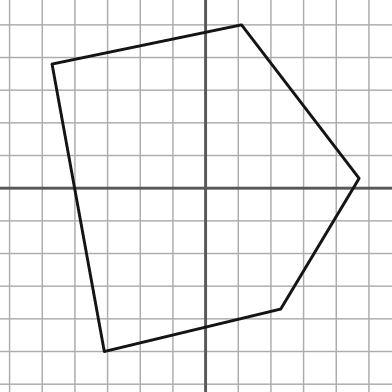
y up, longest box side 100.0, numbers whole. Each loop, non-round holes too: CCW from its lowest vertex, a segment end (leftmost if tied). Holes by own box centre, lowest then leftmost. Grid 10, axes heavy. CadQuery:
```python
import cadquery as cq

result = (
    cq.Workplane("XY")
    .moveTo(-31.0, -50.0)
    .lineTo(23.0, -37.0)
    .lineTo(47.0, 3.0)
    .lineTo(11.0, 50.0)
    .lineTo(-47.0, 38.0)
    .close()
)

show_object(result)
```